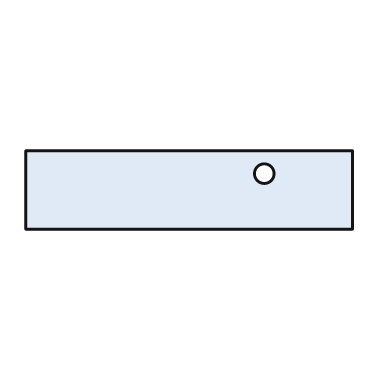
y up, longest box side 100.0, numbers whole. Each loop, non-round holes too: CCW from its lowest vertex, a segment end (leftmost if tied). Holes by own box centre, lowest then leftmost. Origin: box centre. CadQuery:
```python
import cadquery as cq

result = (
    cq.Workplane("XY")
    .moveTo(-50.0, -12.0)
    .lineTo(50.0, -12.0)
    .lineTo(50.0, 12.0)
    .lineTo(-50.0, 12.0)
    .close()
    .moveTo(23.0, 5.0)
    .circle(3.0)
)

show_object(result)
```